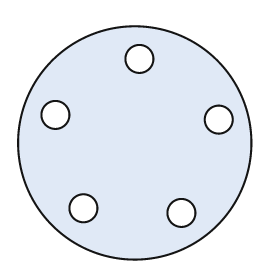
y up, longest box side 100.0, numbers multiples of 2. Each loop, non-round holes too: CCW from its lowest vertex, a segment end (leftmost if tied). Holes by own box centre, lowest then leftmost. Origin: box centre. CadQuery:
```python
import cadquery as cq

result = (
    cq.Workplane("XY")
    .moveTo(0.0, 0.0)
    .circle(50.0)
    .moveTo(20.0, -30.0)
    .circle(6.0)
    .moveTo(-22.0, -28.0)
    .circle(6.0)
    .moveTo(36.0, 10.0)
    .circle(6.0)
    .moveTo(-34.0, 12.0)
    .circle(6.0)
    .moveTo(2.0, 36.0)
    .circle(6.0)
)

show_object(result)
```